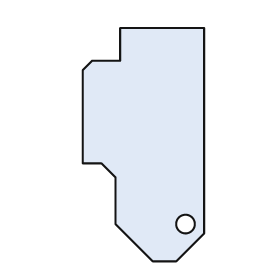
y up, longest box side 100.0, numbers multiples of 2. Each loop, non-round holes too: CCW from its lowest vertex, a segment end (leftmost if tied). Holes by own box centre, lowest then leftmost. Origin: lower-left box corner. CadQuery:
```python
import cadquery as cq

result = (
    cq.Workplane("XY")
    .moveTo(30.0, 0.0)
    .lineTo(40.0, 0.0)
    .lineTo(52.0, 12.0)
    .lineTo(52.0, 100.0)
    .lineTo(16.0, 100.0)
    .lineTo(16.0, 86.0)
    .lineTo(4.0, 86.0)
    .lineTo(0.0, 82.0)
    .lineTo(0.0, 42.0)
    .lineTo(8.0, 42.0)
    .lineTo(14.0, 36.0)
    .lineTo(14.0, 16.0)
    .close()
    .moveTo(44.0, 16.0)
    .circle(4.0)
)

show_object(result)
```